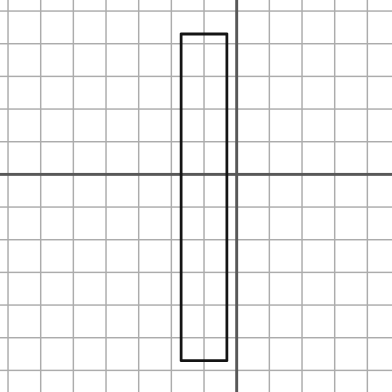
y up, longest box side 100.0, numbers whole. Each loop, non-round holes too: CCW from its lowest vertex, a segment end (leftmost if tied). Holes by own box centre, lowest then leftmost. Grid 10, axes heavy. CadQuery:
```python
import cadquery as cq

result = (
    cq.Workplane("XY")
    .moveTo(-17.0, -57.0)
    .lineTo(-3.0, -57.0)
    .lineTo(-3.0, 43.0)
    .lineTo(-17.0, 43.0)
    .close()
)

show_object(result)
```